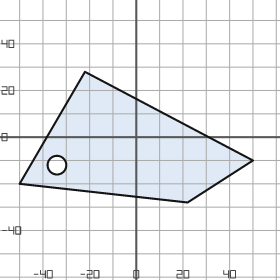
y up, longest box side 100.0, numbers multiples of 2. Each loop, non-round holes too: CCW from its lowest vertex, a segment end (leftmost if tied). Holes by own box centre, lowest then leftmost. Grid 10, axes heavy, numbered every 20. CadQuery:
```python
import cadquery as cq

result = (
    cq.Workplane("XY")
    .moveTo(22.0, -28.0)
    .lineTo(50.0, -10.0)
    .lineTo(-22.0, 28.0)
    .lineTo(-50.0, -20.0)
    .close()
    .moveTo(-34.0, -12.0)
    .circle(4.0)
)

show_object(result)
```